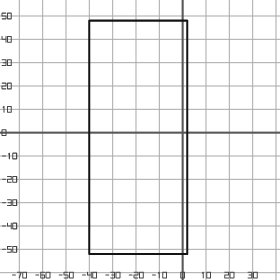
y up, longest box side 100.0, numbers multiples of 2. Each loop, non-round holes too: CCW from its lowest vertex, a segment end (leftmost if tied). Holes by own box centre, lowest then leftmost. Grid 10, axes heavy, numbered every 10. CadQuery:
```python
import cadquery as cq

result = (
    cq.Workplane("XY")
    .moveTo(-40.0, -52.0)
    .lineTo(2.0, -52.0)
    .lineTo(2.0, 48.0)
    .lineTo(-40.0, 48.0)
    .close()
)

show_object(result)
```